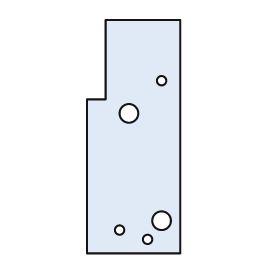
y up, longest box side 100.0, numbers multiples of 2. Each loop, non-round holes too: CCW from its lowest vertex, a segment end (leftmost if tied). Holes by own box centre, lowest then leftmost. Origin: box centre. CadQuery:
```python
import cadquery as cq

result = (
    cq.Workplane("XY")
    .moveTo(-20.0, -50.0)
    .lineTo(20.0, -50.0)
    .lineTo(20.0, 50.0)
    .lineTo(-12.0, 50.0)
    .lineTo(-12.0, 16.0)
    .lineTo(-20.0, 16.0)
    .close()
    .moveTo(6.0, -44.0)
    .circle(2.0)
    .moveTo(-6.0, -40.0)
    .circle(2.0)
    .moveTo(12.0, -36.0)
    .circle(4.0)
    .moveTo(-2.0, 10.0)
    .circle(4.0)
    .moveTo(12.0, 24.0)
    .circle(2.0)
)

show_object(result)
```